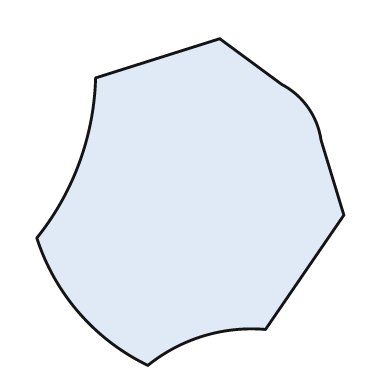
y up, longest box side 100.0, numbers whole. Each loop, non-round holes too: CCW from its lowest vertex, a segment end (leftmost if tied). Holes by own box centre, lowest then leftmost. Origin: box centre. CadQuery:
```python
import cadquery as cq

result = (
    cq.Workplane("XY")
    .moveTo(-13.0, -50.0)
    .threePointArc((4.0, -41.0), (23.0, -39.0))
    .lineTo(47.0, -4.0)
    .lineTo(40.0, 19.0)
    .threePointArc((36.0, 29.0), (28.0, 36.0))
    .lineTo(9.0, 50.0)
    .lineTo(-29.0, 38.0)
    .threePointArc((-34.0, 12.0), (-47.0, -11.0))
    .threePointArc((-34.0, -34.0), (-13.0, -50.0))
    .close()
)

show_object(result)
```